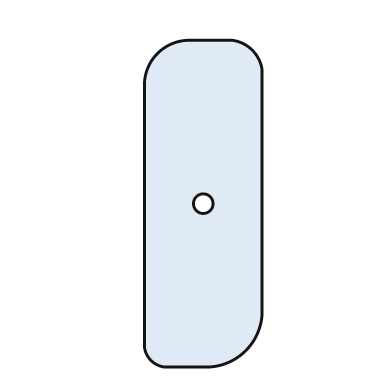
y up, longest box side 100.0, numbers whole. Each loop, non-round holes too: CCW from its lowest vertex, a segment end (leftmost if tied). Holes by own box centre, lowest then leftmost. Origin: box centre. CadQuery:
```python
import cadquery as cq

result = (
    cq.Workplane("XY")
    .moveTo(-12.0, -50.0)
    .lineTo(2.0, -50.0)
    .threePointArc((13.0, -45.0), (18.0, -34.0))
    .lineTo(18.0, 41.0)
    .threePointArc((15.0, 47.0), (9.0, 50.0))
    .lineTo(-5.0, 50.0)
    .threePointArc((-14.0, 46.0), (-18.0, 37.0))
    .lineTo(-18.0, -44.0)
    .threePointArc((-16.0, -48.0), (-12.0, -50.0))
    .close()
    .moveTo(0.0, 0.0)
    .circle(3.0)
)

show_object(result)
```